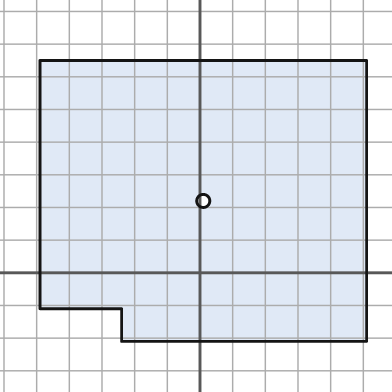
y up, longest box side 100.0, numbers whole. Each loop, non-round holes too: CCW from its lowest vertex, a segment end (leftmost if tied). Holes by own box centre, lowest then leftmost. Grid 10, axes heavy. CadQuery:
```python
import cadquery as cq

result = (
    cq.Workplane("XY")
    .moveTo(-24.0, -21.0)
    .lineTo(51.0, -21.0)
    .lineTo(51.0, 65.0)
    .lineTo(-49.0, 65.0)
    .lineTo(-49.0, -11.0)
    .lineTo(-24.0, -11.0)
    .close()
    .moveTo(1.0, 22.0)
    .circle(2.0)
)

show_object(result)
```